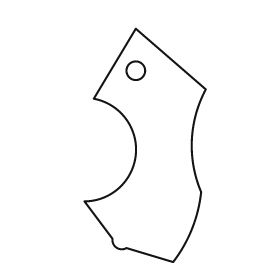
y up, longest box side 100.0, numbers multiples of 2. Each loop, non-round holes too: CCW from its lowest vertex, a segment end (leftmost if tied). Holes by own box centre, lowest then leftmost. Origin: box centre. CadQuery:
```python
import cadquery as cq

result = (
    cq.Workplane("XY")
    .moveTo(12.0, -50.0)
    .threePointArc((20.0, -36.0), (24.0, -20.0))
    .threePointArc((20.0, 2.0), (26.0, 24.0))
    .lineTo(-4.0, 50.0)
    .lineTo(-22.0, 20.0)
    .threePointArc((-4.0, -4.0), (-26.0, -24.0))
    .lineTo(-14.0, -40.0)
    .threePointArc((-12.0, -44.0), (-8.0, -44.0))
    .close()
    .moveTo(-4.0, 32.0)
    .circle(4.0)
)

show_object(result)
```